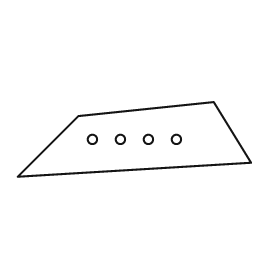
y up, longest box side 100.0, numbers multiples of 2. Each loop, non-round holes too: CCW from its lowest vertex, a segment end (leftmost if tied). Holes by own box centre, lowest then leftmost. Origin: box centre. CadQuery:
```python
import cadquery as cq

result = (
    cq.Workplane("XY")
    .moveTo(-50.0, -16.0)
    .lineTo(50.0, -10.0)
    .lineTo(34.0, 16.0)
    .lineTo(-24.0, 10.0)
    .close()
    .moveTo(-18.0, 0.0)
    .circle(2.0)
    .moveTo(-6.0, 0.0)
    .circle(2.0)
    .moveTo(6.0, 0.0)
    .circle(2.0)
    .moveTo(18.0, 0.0)
    .circle(2.0)
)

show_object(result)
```